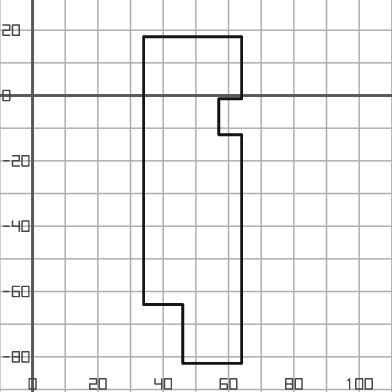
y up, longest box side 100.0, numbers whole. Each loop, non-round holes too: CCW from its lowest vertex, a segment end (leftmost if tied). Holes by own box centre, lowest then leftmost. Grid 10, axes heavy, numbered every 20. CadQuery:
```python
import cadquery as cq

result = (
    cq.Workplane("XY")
    .moveTo(46.0, -82.0)
    .lineTo(64.0, -82.0)
    .lineTo(64.0, -12.0)
    .lineTo(57.0, -12.0)
    .lineTo(57.0, -1.0)
    .lineTo(64.0, -1.0)
    .lineTo(64.0, 18.0)
    .lineTo(34.0, 18.0)
    .lineTo(34.0, -64.0)
    .lineTo(46.0, -64.0)
    .close()
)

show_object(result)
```